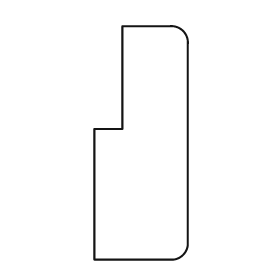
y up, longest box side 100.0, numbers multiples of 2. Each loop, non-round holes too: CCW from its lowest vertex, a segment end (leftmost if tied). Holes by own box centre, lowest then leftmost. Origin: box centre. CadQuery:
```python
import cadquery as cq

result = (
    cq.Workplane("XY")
    .moveTo(-20.0, -50.0)
    .lineTo(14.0, -50.0)
    .threePointArc((18.0, -48.0), (20.0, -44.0))
    .lineTo(20.0, 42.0)
    .threePointArc((18.0, 48.0), (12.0, 50.0))
    .lineTo(-8.0, 50.0)
    .lineTo(-8.0, 6.0)
    .lineTo(-20.0, 6.0)
    .close()
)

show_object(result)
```